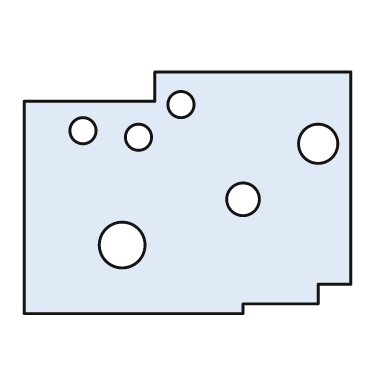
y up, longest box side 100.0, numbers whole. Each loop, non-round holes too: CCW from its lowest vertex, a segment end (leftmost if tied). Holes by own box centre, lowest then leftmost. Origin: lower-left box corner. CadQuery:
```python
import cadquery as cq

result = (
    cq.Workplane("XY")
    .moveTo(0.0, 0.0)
    .lineTo(67.0, 0.0)
    .lineTo(67.0, 3.0)
    .lineTo(90.0, 3.0)
    .lineTo(90.0, 9.0)
    .lineTo(100.0, 9.0)
    .lineTo(100.0, 74.0)
    .lineTo(40.0, 74.0)
    .lineTo(40.0, 65.0)
    .lineTo(0.0, 65.0)
    .close()
    .moveTo(30.0, 21.0)
    .circle(7.0)
    .moveTo(67.0, 35.0)
    .circle(5.0)
    .moveTo(90.0, 52.0)
    .circle(6.0)
    .moveTo(35.0, 54.0)
    .circle(4.0)
    .moveTo(18.0, 56.0)
    .circle(4.0)
    .moveTo(48.0, 64.0)
    .circle(4.0)
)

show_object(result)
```